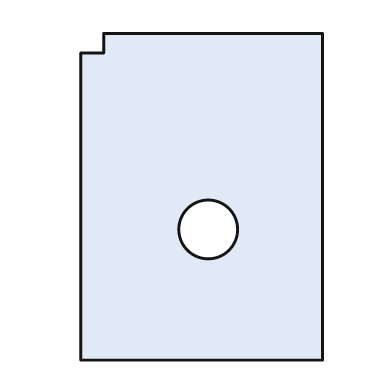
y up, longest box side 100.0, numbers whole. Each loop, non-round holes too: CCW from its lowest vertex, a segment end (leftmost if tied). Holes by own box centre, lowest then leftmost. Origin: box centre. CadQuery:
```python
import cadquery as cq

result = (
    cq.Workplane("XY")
    .moveTo(-37.0, -50.0)
    .lineTo(37.0, -50.0)
    .lineTo(37.0, 50.0)
    .lineTo(-30.0, 50.0)
    .lineTo(-30.0, 44.0)
    .lineTo(-37.0, 44.0)
    .close()
    .moveTo(2.0, -10.0)
    .circle(9.0)
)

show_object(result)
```